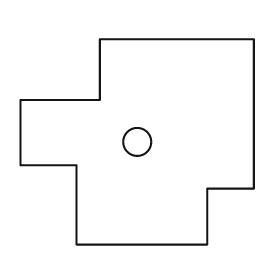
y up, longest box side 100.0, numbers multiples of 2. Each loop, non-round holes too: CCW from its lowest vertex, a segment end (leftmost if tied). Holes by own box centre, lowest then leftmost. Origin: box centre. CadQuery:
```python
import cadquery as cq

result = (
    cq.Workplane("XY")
    .moveTo(-26.0, -44.0)
    .lineTo(30.0, -44.0)
    .lineTo(30.0, -20.0)
    .lineTo(50.0, -20.0)
    .lineTo(50.0, 44.0)
    .lineTo(-16.0, 44.0)
    .lineTo(-16.0, 18.0)
    .lineTo(-50.0, 18.0)
    .lineTo(-50.0, -10.0)
    .lineTo(-26.0, -10.0)
    .close()
    .moveTo(0.0, 0.0)
    .circle(6.0)
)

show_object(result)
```